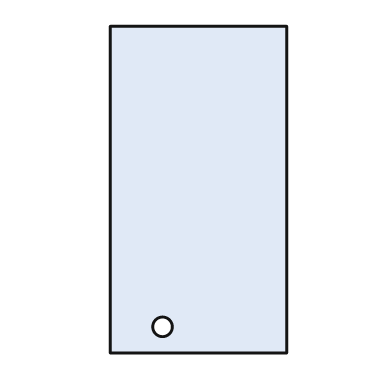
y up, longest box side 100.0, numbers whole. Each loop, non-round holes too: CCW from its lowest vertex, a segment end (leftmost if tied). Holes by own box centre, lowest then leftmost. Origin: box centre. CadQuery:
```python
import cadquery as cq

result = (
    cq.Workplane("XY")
    .moveTo(-27.0, -50.0)
    .lineTo(27.0, -50.0)
    .lineTo(27.0, 50.0)
    .lineTo(-27.0, 50.0)
    .close()
    .moveTo(-11.0, -42.0)
    .circle(3.0)
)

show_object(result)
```